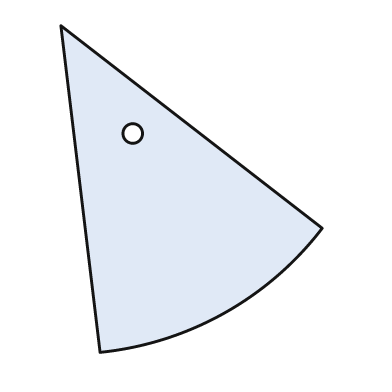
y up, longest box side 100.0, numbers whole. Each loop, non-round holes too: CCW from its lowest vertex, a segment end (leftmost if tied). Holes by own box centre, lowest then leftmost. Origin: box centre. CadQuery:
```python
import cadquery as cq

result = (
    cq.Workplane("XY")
    .moveTo(-28.0, -50.0)
    .threePointArc((10.0, -38.0), (40.0, -12.0))
    .lineTo(-40.0, 50.0)
    .close()
    .moveTo(-18.0, 17.0)
    .circle(3.0)
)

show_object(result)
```